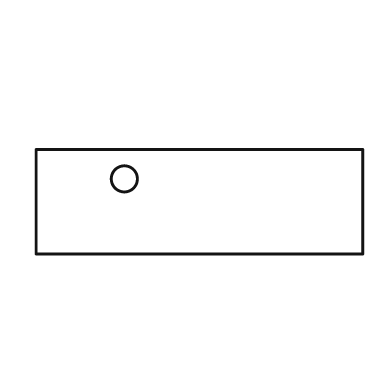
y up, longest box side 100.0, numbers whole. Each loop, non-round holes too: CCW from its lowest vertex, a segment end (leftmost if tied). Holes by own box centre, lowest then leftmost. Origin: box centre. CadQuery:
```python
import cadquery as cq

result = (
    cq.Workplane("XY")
    .moveTo(-50.0, -16.0)
    .lineTo(50.0, -16.0)
    .lineTo(50.0, 16.0)
    .lineTo(-50.0, 16.0)
    .close()
    .moveTo(-23.0, 7.0)
    .circle(4.0)
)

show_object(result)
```